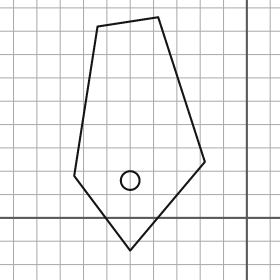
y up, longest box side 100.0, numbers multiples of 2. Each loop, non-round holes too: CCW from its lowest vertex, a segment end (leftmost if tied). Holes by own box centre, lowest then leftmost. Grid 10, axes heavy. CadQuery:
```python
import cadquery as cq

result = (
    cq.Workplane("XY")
    .moveTo(-50.0, -14.0)
    .lineTo(-18.0, 24.0)
    .lineTo(-38.0, 86.0)
    .lineTo(-64.0, 82.0)
    .lineTo(-74.0, 18.0)
    .close()
    .moveTo(-50.0, 16.0)
    .circle(4.0)
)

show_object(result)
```